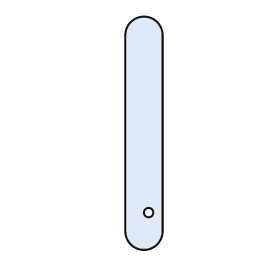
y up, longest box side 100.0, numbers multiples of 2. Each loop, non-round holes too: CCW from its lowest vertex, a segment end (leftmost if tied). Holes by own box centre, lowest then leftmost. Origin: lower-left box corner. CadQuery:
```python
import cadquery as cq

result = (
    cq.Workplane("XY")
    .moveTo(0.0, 8.0)
    .threePointArc((8.0, 0.0), (16.0, 8.0))
    .lineTo(16.0, 92.0)
    .threePointArc((8.0, 100.0), (0.0, 92.0))
    .close()
    .moveTo(10.0, 16.0)
    .circle(2.0)
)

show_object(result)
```